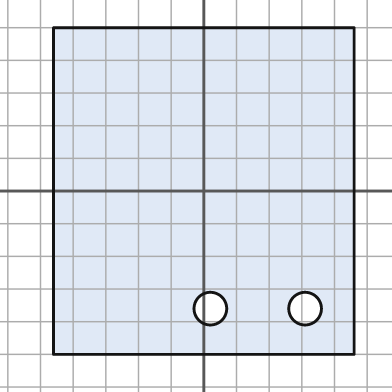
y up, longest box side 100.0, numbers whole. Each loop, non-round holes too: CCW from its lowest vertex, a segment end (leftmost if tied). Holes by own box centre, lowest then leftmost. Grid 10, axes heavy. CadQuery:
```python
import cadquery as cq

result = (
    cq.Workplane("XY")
    .moveTo(-46.0, -50.0)
    .lineTo(46.0, -50.0)
    .lineTo(46.0, 50.0)
    .lineTo(-46.0, 50.0)
    .close()
    .moveTo(2.0, -36.0)
    .circle(5.0)
    .moveTo(31.0, -36.0)
    .circle(5.0)
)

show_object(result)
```